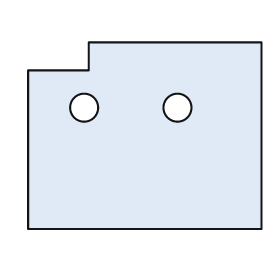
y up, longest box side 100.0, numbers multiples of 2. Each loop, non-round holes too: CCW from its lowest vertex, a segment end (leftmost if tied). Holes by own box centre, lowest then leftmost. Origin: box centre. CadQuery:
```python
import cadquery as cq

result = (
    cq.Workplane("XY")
    .moveTo(-50.0, -40.0)
    .lineTo(50.0, -40.0)
    .lineTo(50.0, 40.0)
    .lineTo(-24.0, 40.0)
    .lineTo(-24.0, 28.0)
    .lineTo(-50.0, 28.0)
    .close()
    .moveTo(-26.0, 12.0)
    .circle(6.0)
    .moveTo(14.0, 12.0)
    .circle(6.0)
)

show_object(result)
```